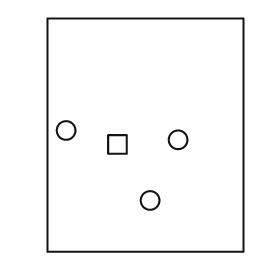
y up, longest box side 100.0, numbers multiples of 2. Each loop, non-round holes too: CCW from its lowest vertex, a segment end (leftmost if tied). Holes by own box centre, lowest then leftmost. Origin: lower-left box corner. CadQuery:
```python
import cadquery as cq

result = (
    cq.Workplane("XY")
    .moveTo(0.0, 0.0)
    .lineTo(84.0, 0.0)
    .lineTo(84.0, 100.0)
    .lineTo(0.0, 100.0)
    .close()
    .moveTo(44.0, 22.0)
    .circle(4.0)
    .moveTo(26.0, 42.0)
    .lineTo(34.0, 42.0)
    .lineTo(34.0, 50.0)
    .lineTo(26.0, 50.0)
    .close()
    .moveTo(56.0, 48.0)
    .circle(4.0)
    .moveTo(8.0, 52.0)
    .circle(4.0)
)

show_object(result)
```